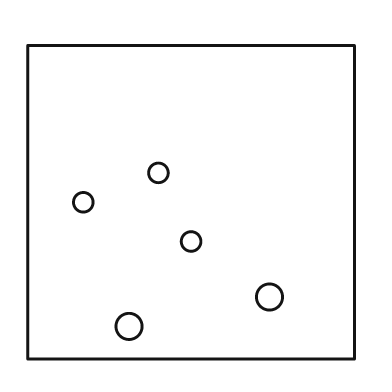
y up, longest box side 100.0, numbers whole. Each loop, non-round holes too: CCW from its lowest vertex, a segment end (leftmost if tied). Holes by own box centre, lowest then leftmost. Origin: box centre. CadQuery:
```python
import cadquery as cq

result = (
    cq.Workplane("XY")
    .moveTo(-50.0, -48.0)
    .lineTo(50.0, -48.0)
    .lineTo(50.0, 48.0)
    .lineTo(-50.0, 48.0)
    .close()
    .moveTo(-19.0, -38.0)
    .circle(4.0)
    .moveTo(24.0, -29.0)
    .circle(4.0)
    .moveTo(0.0, -12.0)
    .circle(3.0)
    .moveTo(-33.0, 0.0)
    .circle(3.0)
    .moveTo(-10.0, 9.0)
    .circle(3.0)
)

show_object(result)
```